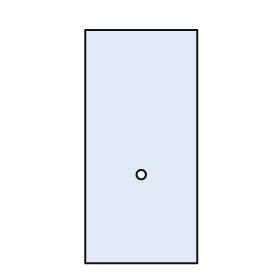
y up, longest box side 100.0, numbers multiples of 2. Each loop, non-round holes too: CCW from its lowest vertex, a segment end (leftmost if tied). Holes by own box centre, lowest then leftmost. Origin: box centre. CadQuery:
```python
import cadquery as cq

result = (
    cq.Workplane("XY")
    .moveTo(-24.0, -50.0)
    .lineTo(24.0, -50.0)
    .lineTo(24.0, 50.0)
    .lineTo(-24.0, 50.0)
    .close()
    .moveTo(0.0, -12.0)
    .circle(2.0)
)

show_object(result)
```